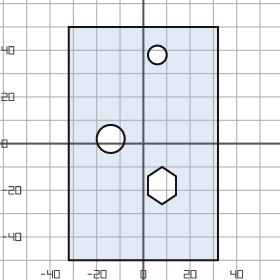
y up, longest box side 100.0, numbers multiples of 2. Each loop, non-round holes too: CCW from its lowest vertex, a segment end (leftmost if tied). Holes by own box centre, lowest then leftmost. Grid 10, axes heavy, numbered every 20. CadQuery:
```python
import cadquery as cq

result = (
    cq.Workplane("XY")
    .moveTo(-32.0, -50.0)
    .lineTo(32.0, -50.0)
    .lineTo(32.0, 50.0)
    .lineTo(-32.0, 50.0)
    .close()
    .moveTo(8.0, -26.0)
    .lineTo(14.0, -22.0)
    .lineTo(14.0, -14.0)
    .lineTo(8.0, -10.0)
    .lineTo(2.0, -14.0)
    .lineTo(2.0, -22.0)
    .close()
    .moveTo(-14.0, 2.0)
    .circle(6.0)
    .moveTo(6.0, 38.0)
    .circle(4.0)
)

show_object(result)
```